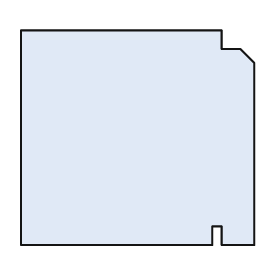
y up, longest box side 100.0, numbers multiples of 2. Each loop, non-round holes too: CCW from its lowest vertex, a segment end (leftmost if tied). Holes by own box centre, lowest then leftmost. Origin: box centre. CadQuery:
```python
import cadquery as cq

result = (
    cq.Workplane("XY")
    .moveTo(-50.0, -46.0)
    .lineTo(32.0, -46.0)
    .lineTo(32.0, -38.0)
    .lineTo(36.0, -38.0)
    .lineTo(36.0, -46.0)
    .lineTo(50.0, -46.0)
    .lineTo(50.0, 32.0)
    .lineTo(44.0, 38.0)
    .lineTo(36.0, 38.0)
    .lineTo(36.0, 46.0)
    .lineTo(-50.0, 46.0)
    .close()
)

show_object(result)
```